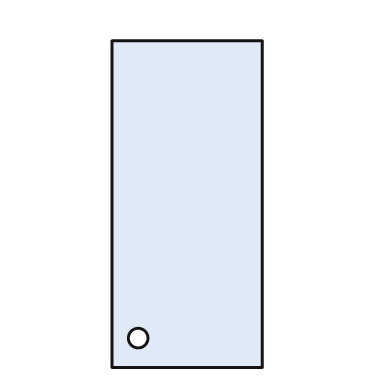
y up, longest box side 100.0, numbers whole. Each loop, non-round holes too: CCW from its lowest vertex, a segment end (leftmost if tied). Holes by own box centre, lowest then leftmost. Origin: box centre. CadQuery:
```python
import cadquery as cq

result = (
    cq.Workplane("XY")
    .moveTo(-23.0, -50.0)
    .lineTo(23.0, -50.0)
    .lineTo(23.0, 50.0)
    .lineTo(-23.0, 50.0)
    .close()
    .moveTo(-15.0, -41.0)
    .circle(3.0)
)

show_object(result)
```